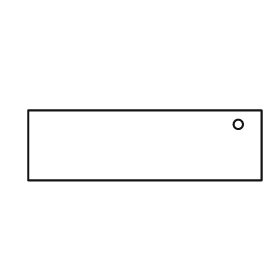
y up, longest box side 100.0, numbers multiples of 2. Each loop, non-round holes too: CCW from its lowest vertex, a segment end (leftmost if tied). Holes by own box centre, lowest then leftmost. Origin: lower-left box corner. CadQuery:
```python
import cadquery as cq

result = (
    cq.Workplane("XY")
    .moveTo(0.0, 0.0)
    .lineTo(100.0, 0.0)
    .lineTo(100.0, 30.0)
    .lineTo(0.0, 30.0)
    .close()
    .moveTo(90.0, 24.0)
    .circle(2.0)
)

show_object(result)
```